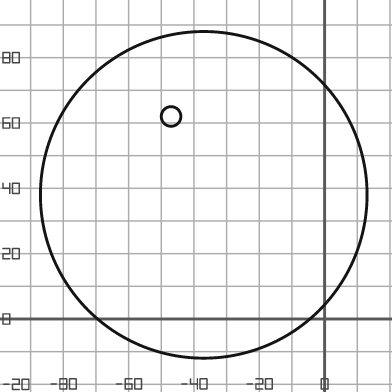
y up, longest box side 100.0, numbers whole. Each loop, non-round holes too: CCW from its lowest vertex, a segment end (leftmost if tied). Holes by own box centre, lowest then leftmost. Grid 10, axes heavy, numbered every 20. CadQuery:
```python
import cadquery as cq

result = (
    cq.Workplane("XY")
    .moveTo(-37.0, 38.0)
    .circle(50.0)
    .moveTo(-47.0, 62.0)
    .circle(3.0)
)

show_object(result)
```